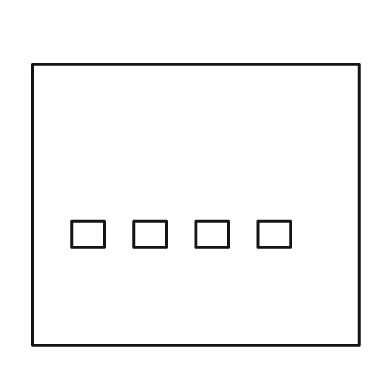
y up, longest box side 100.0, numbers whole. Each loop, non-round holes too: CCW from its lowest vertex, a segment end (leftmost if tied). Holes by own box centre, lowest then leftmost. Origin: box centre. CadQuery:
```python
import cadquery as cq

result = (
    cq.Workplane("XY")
    .moveTo(-50.0, -43.0)
    .lineTo(50.0, -43.0)
    .lineTo(50.0, 43.0)
    .lineTo(-50.0, 43.0)
    .close()
    .moveTo(-38.0, -13.0)
    .lineTo(-28.0, -13.0)
    .lineTo(-28.0, -5.0)
    .lineTo(-38.0, -5.0)
    .close()
    .moveTo(-19.0, -13.0)
    .lineTo(-9.0, -13.0)
    .lineTo(-9.0, -5.0)
    .lineTo(-19.0, -5.0)
    .close()
    .moveTo(0.0, -13.0)
    .lineTo(10.0, -13.0)
    .lineTo(10.0, -5.0)
    .lineTo(0.0, -5.0)
    .close()
    .moveTo(19.0, -13.0)
    .lineTo(29.0, -13.0)
    .lineTo(29.0, -5.0)
    .lineTo(19.0, -5.0)
    .close()
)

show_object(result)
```